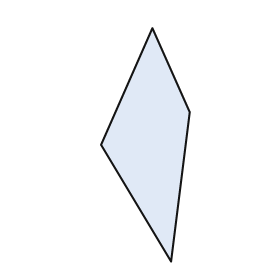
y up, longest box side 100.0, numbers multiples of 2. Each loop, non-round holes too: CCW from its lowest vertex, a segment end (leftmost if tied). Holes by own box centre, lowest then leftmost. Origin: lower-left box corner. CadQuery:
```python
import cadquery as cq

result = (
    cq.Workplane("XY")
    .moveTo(30.0, 0.0)
    .lineTo(38.0, 64.0)
    .lineTo(22.0, 100.0)
    .lineTo(0.0, 50.0)
    .close()
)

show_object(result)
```